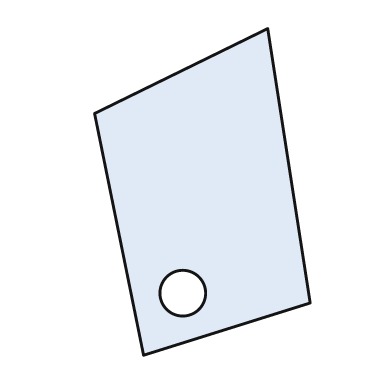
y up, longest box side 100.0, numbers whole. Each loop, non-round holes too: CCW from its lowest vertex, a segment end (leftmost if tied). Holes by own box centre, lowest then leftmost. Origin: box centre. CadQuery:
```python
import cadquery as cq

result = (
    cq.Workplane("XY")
    .moveTo(-18.0, -50.0)
    .lineTo(33.0, -34.0)
    .lineTo(20.0, 50.0)
    .lineTo(-33.0, 24.0)
    .close()
    .moveTo(-6.0, -31.0)
    .circle(7.0)
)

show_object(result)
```